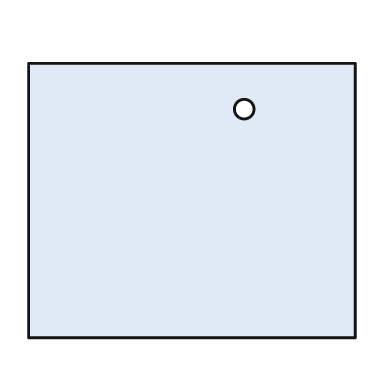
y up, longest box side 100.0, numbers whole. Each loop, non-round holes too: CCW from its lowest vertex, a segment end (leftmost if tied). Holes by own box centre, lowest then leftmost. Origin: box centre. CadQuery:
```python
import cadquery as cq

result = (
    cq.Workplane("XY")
    .moveTo(-50.0, -42.0)
    .lineTo(50.0, -42.0)
    .lineTo(50.0, 42.0)
    .lineTo(-50.0, 42.0)
    .close()
    .moveTo(16.0, 28.0)
    .circle(3.0)
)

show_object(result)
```